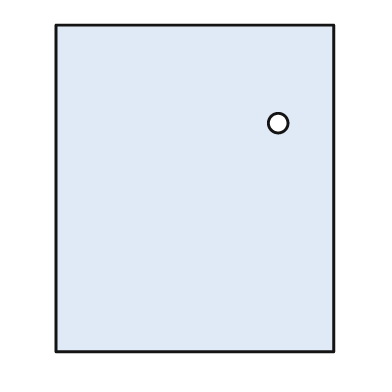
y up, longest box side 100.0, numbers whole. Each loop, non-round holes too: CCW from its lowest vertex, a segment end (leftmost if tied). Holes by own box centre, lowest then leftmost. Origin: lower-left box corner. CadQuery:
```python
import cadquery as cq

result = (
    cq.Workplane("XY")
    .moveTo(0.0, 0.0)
    .lineTo(85.0, 0.0)
    .lineTo(85.0, 100.0)
    .lineTo(0.0, 100.0)
    .close()
    .moveTo(68.0, 70.0)
    .circle(3.0)
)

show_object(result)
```